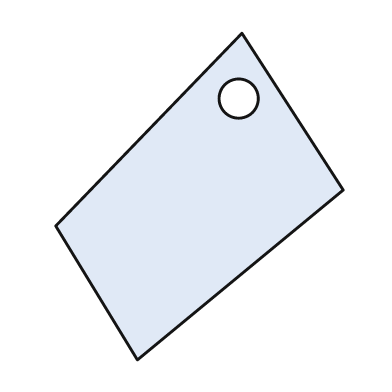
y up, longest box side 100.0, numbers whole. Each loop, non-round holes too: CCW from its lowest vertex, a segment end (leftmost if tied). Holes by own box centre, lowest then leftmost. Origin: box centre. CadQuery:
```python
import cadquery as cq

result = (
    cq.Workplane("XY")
    .moveTo(-19.0, -50.0)
    .lineTo(44.0, 2.0)
    .lineTo(13.0, 50.0)
    .lineTo(-44.0, -9.0)
    .close()
    .moveTo(12.0, 30.0)
    .circle(6.0)
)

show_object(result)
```